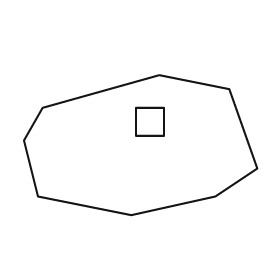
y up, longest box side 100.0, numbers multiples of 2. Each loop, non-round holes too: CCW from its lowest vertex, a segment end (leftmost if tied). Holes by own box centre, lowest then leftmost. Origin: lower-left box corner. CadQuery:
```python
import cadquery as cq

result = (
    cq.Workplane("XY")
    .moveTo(46.0, 0.0)
    .lineTo(82.0, 8.0)
    .lineTo(100.0, 20.0)
    .lineTo(88.0, 54.0)
    .lineTo(58.0, 60.0)
    .lineTo(8.0, 46.0)
    .lineTo(0.0, 32.0)
    .lineTo(6.0, 8.0)
    .close()
    .moveTo(48.0, 34.0)
    .lineTo(60.0, 34.0)
    .lineTo(60.0, 46.0)
    .lineTo(48.0, 46.0)
    .close()
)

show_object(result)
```